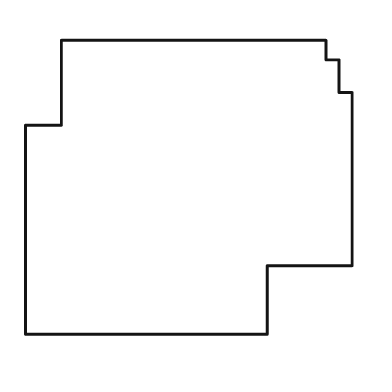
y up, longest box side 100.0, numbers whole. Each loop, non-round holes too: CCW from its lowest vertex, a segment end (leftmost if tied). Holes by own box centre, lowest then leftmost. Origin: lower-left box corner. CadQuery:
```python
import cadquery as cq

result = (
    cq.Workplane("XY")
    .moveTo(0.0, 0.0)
    .lineTo(74.0, 0.0)
    .lineTo(74.0, 21.0)
    .lineTo(100.0, 21.0)
    .lineTo(100.0, 74.0)
    .lineTo(96.0, 74.0)
    .lineTo(96.0, 84.0)
    .lineTo(92.0, 84.0)
    .lineTo(92.0, 90.0)
    .lineTo(11.0, 90.0)
    .lineTo(11.0, 64.0)
    .lineTo(0.0, 64.0)
    .close()
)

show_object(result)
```